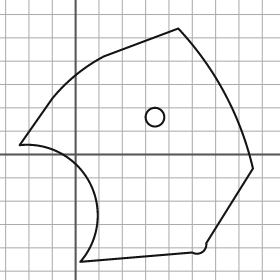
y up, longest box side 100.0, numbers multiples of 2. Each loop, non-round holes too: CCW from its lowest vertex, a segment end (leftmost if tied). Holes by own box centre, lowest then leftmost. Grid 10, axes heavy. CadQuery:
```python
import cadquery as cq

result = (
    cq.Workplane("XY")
    .moveTo(2.0, -46.0)
    .lineTo(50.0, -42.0)
    .threePointArc((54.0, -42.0), (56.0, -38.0))
    .lineTo(76.0, -6.0)
    .threePointArc((64.0, 26.0), (44.0, 54.0))
    .lineTo(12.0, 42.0)
    .threePointArc((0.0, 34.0), (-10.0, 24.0))
    .lineTo(-24.0, 4.0)
    .threePointArc((6.0, -12.0), (2.0, -46.0))
    .close()
    .moveTo(34.0, 16.0)
    .circle(4.0)
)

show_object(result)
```